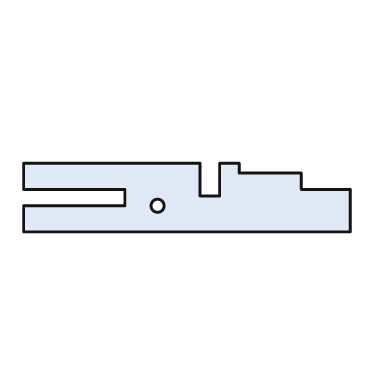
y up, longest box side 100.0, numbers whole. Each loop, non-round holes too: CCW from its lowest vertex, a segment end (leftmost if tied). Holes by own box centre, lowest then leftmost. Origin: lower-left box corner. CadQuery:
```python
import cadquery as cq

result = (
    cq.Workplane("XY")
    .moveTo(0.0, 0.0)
    .lineTo(100.0, 0.0)
    .lineTo(100.0, 13.0)
    .lineTo(85.0, 13.0)
    .lineTo(85.0, 18.0)
    .lineTo(66.0, 18.0)
    .lineTo(66.0, 21.0)
    .lineTo(60.0, 21.0)
    .lineTo(60.0, 11.0)
    .lineTo(54.0, 11.0)
    .lineTo(54.0, 21.0)
    .lineTo(0.0, 21.0)
    .lineTo(0.0, 13.0)
    .lineTo(31.0, 13.0)
    .lineTo(31.0, 8.0)
    .lineTo(0.0, 8.0)
    .close()
    .moveTo(41.0, 8.0)
    .circle(2.0)
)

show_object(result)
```